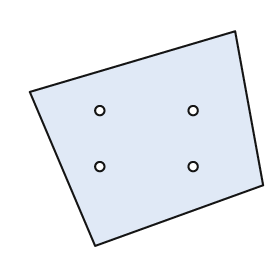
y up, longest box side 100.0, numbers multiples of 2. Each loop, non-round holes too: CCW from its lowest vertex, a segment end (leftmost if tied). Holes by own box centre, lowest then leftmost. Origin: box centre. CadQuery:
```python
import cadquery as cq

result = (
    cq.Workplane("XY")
    .moveTo(-22.0, -46.0)
    .lineTo(50.0, -20.0)
    .lineTo(38.0, 46.0)
    .lineTo(-50.0, 20.0)
    .close()
    .moveTo(-20.0, -12.0)
    .circle(2.0)
    .moveTo(20.0, -12.0)
    .circle(2.0)
    .moveTo(-20.0, 12.0)
    .circle(2.0)
    .moveTo(20.0, 12.0)
    .circle(2.0)
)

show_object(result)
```